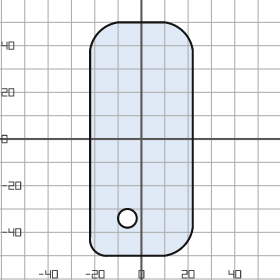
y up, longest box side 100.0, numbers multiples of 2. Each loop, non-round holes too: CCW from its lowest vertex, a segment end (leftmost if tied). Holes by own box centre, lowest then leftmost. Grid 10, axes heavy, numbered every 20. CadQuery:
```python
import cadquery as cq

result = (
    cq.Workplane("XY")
    .moveTo(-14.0, -50.0)
    .lineTo(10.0, -50.0)
    .threePointArc((18.0, -46.0), (22.0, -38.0))
    .lineTo(22.0, 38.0)
    .threePointArc((18.0, 46.0), (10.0, 50.0))
    .lineTo(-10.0, 50.0)
    .threePointArc((-18.0, 46.0), (-22.0, 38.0))
    .lineTo(-22.0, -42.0)
    .threePointArc((-20.0, -48.0), (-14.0, -50.0))
    .close()
    .moveTo(-6.0, -34.0)
    .circle(4.0)
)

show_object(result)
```